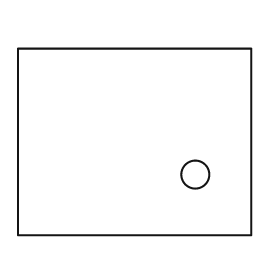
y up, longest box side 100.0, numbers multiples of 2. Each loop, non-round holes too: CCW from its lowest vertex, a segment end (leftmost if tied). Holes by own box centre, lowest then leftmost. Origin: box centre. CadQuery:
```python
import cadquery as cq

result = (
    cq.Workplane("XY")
    .moveTo(-50.0, -40.0)
    .lineTo(50.0, -40.0)
    .lineTo(50.0, 40.0)
    .lineTo(-50.0, 40.0)
    .close()
    .moveTo(26.0, -14.0)
    .circle(6.0)
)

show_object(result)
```